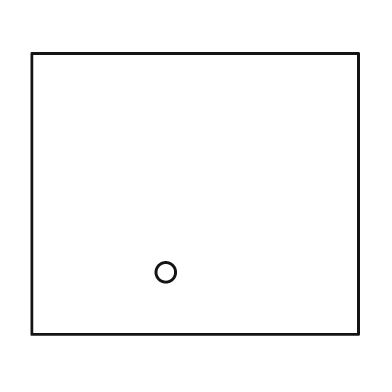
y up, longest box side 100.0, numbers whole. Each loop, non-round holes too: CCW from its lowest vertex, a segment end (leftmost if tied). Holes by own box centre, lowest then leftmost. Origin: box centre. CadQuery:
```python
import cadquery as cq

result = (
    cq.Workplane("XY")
    .moveTo(-50.0, -43.0)
    .lineTo(50.0, -43.0)
    .lineTo(50.0, 43.0)
    .lineTo(-50.0, 43.0)
    .close()
    .moveTo(-9.0, -24.0)
    .circle(3.0)
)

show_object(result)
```